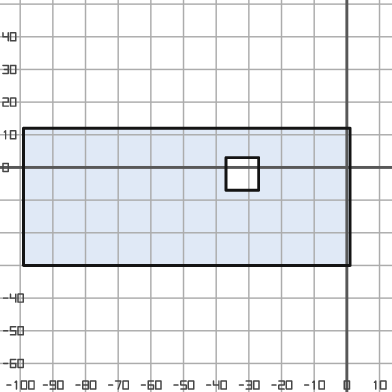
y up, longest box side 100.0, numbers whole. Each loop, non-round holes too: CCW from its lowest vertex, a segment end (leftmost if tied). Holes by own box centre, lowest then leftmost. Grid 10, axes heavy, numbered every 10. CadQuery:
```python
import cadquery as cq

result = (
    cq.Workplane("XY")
    .moveTo(-99.0, -30.0)
    .lineTo(1.0, -30.0)
    .lineTo(1.0, 12.0)
    .lineTo(-99.0, 12.0)
    .close()
    .moveTo(-37.0, -7.0)
    .lineTo(-27.0, -7.0)
    .lineTo(-27.0, 3.0)
    .lineTo(-37.0, 3.0)
    .close()
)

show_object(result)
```